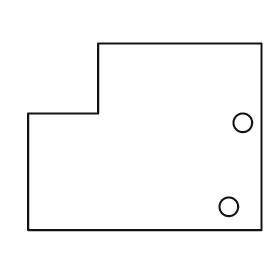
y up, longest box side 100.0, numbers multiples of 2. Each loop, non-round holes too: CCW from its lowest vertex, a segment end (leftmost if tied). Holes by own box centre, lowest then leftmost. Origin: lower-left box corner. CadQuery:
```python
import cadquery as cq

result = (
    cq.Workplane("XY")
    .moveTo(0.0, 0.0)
    .lineTo(100.0, 0.0)
    .lineTo(100.0, 80.0)
    .lineTo(30.0, 80.0)
    .lineTo(30.0, 50.0)
    .lineTo(0.0, 50.0)
    .close()
    .moveTo(86.0, 10.0)
    .circle(4.0)
    .moveTo(92.0, 46.0)
    .circle(4.0)
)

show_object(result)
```